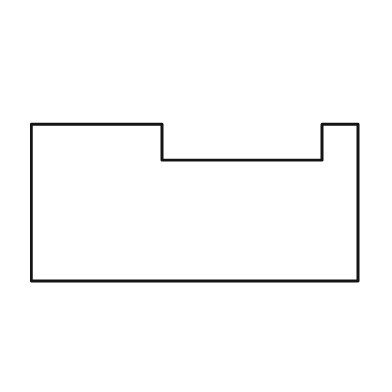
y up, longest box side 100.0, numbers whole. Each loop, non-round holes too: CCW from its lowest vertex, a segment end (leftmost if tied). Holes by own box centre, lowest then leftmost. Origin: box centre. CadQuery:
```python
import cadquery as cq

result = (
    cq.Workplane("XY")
    .moveTo(-50.0, -24.0)
    .lineTo(50.0, -24.0)
    .lineTo(50.0, 24.0)
    .lineTo(39.0, 24.0)
    .lineTo(39.0, 13.0)
    .lineTo(-10.0, 13.0)
    .lineTo(-10.0, 24.0)
    .lineTo(-50.0, 24.0)
    .close()
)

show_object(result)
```